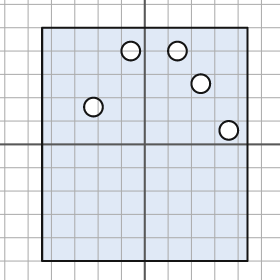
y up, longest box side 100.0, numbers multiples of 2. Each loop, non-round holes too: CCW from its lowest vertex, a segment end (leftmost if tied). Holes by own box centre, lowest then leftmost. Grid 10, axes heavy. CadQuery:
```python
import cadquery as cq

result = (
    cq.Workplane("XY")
    .moveTo(-44.0, -50.0)
    .lineTo(44.0, -50.0)
    .lineTo(44.0, 50.0)
    .lineTo(-44.0, 50.0)
    .close()
    .moveTo(36.0, 6.0)
    .circle(4.0)
    .moveTo(-22.0, 16.0)
    .circle(4.0)
    .moveTo(24.0, 26.0)
    .circle(4.0)
    .moveTo(-6.0, 40.0)
    .circle(4.0)
    .moveTo(14.0, 40.0)
    .circle(4.0)
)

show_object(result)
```